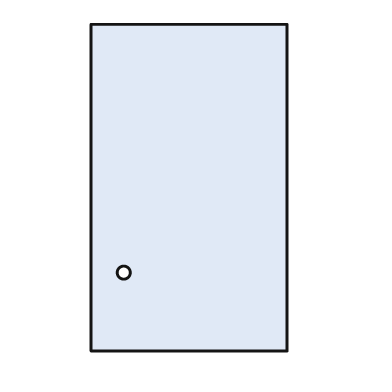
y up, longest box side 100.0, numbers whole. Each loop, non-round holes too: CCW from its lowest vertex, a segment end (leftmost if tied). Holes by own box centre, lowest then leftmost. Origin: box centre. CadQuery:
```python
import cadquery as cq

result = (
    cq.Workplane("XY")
    .moveTo(-30.0, -50.0)
    .lineTo(30.0, -50.0)
    .lineTo(30.0, 50.0)
    .lineTo(-30.0, 50.0)
    .close()
    .moveTo(-20.0, -26.0)
    .circle(2.0)
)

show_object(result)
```